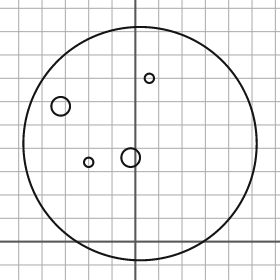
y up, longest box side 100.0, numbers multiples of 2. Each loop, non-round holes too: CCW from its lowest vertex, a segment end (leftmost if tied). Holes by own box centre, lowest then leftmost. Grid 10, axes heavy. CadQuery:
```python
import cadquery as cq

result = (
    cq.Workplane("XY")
    .moveTo(2.0, 42.0)
    .circle(50.0)
    .moveTo(-20.0, 34.0)
    .circle(2.0)
    .moveTo(-2.0, 36.0)
    .circle(4.0)
    .moveTo(-32.0, 58.0)
    .circle(4.0)
    .moveTo(6.0, 70.0)
    .circle(2.0)
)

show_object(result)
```